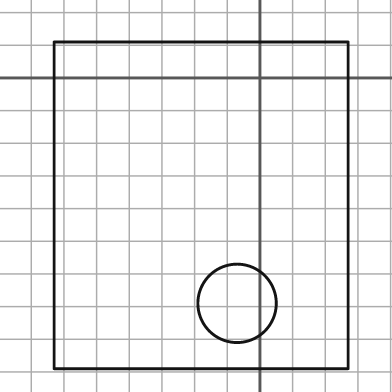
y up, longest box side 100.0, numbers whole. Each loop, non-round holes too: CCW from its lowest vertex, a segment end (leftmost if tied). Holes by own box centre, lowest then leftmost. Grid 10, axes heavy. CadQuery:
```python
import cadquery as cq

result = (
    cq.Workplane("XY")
    .moveTo(-63.0, -89.0)
    .lineTo(27.0, -89.0)
    .lineTo(27.0, 11.0)
    .lineTo(-63.0, 11.0)
    .close()
    .moveTo(-7.0, -69.0)
    .circle(12.0)
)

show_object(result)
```